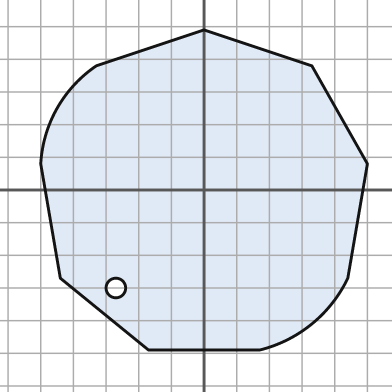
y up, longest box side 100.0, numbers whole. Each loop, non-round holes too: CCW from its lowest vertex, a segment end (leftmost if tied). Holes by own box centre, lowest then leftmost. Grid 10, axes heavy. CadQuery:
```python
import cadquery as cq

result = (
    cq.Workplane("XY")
    .moveTo(-17.0, -49.0)
    .lineTo(17.0, -49.0)
    .threePointArc((33.0, -41.0), (44.0, -27.0))
    .lineTo(50.0, 8.0)
    .lineTo(33.0, 38.0)
    .lineTo(0.0, 49.0)
    .lineTo(-33.0, 38.0)
    .threePointArc((-45.0, 25.0), (-50.0, 8.0))
    .lineTo(-44.0, -27.0)
    .close()
    .moveTo(-27.0, -30.0)
    .circle(3.0)
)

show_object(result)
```